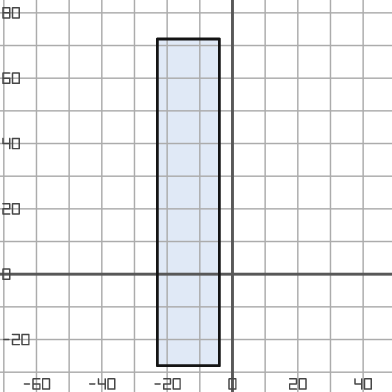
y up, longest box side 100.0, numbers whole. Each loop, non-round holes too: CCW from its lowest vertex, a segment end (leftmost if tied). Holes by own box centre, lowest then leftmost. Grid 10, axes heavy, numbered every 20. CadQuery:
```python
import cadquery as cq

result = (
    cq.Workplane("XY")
    .moveTo(-23.0, -28.0)
    .lineTo(-4.0, -28.0)
    .lineTo(-4.0, 72.0)
    .lineTo(-23.0, 72.0)
    .close()
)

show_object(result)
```